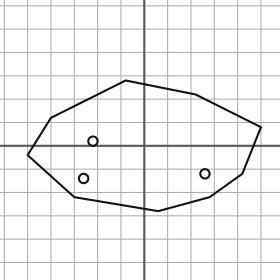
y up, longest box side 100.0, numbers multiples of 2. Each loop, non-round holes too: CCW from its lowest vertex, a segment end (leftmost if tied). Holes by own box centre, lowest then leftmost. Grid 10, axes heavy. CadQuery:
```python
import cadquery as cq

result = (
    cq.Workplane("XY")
    .moveTo(6.0, -28.0)
    .lineTo(28.0, -22.0)
    .lineTo(42.0, -12.0)
    .lineTo(50.0, 8.0)
    .lineTo(22.0, 22.0)
    .lineTo(-8.0, 28.0)
    .lineTo(-40.0, 12.0)
    .lineTo(-50.0, -4.0)
    .lineTo(-30.0, -22.0)
    .close()
    .moveTo(-26.0, -14.0)
    .circle(2.0)
    .moveTo(26.0, -12.0)
    .circle(2.0)
    .moveTo(-22.0, 2.0)
    .circle(2.0)
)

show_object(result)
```